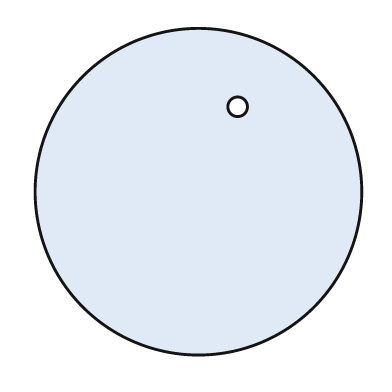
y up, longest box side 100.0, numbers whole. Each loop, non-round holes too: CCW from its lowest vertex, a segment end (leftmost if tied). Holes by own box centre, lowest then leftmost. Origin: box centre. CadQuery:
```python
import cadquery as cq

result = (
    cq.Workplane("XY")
    .moveTo(0.0, 0.0)
    .circle(50.0)
    .moveTo(12.0, 26.0)
    .circle(3.0)
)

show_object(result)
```